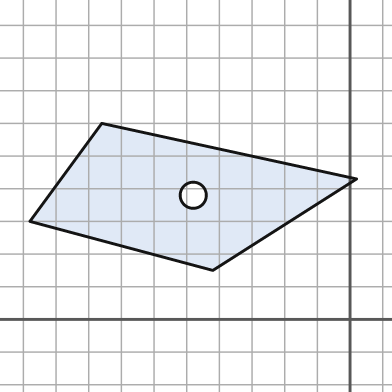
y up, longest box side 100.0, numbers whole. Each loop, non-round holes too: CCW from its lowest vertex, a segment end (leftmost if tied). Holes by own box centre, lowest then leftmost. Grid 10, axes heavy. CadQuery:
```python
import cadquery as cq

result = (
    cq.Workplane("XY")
    .moveTo(-42.0, 15.0)
    .lineTo(2.0, 43.0)
    .lineTo(-76.0, 60.0)
    .lineTo(-98.0, 30.0)
    .close()
    .moveTo(-48.0, 38.0)
    .circle(4.0)
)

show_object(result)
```